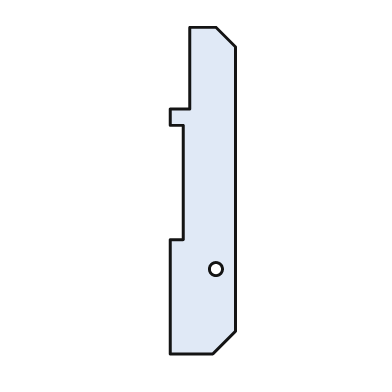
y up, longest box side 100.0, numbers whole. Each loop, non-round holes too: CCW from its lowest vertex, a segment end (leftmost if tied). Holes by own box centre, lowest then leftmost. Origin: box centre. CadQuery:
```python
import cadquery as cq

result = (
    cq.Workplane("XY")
    .moveTo(-10.0, -50.0)
    .lineTo(3.0, -50.0)
    .lineTo(10.0, -43.0)
    .lineTo(10.0, 44.0)
    .lineTo(4.0, 50.0)
    .lineTo(-4.0, 50.0)
    .lineTo(-4.0, 25.0)
    .lineTo(-10.0, 25.0)
    .lineTo(-10.0, 20.0)
    .lineTo(-6.0, 20.0)
    .lineTo(-6.0, -15.0)
    .lineTo(-10.0, -15.0)
    .close()
    .moveTo(4.0, -24.0)
    .circle(2.0)
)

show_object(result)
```